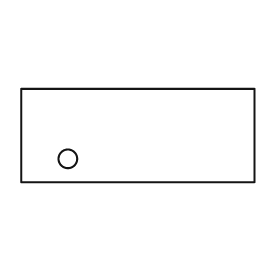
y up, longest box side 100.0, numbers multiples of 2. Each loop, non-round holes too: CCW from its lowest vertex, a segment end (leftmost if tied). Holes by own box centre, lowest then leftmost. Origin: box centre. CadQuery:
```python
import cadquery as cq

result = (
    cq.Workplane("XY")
    .moveTo(-50.0, -20.0)
    .lineTo(50.0, -20.0)
    .lineTo(50.0, 20.0)
    .lineTo(-50.0, 20.0)
    .close()
    .moveTo(-30.0, -10.0)
    .circle(4.0)
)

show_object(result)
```